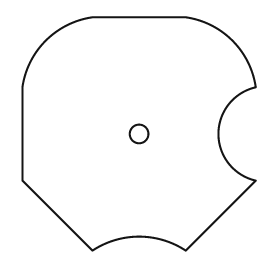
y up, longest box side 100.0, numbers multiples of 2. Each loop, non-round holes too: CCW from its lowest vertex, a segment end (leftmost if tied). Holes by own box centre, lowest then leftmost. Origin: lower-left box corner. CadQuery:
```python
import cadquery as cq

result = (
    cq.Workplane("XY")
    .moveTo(30.0, 0.0)
    .threePointArc((50.0, 6.0), (70.0, 0.0))
    .lineTo(100.0, 30.0)
    .threePointArc((84.0, 50.0), (100.0, 70.0))
    .threePointArc((90.0, 90.0), (70.0, 100.0))
    .lineTo(30.0, 100.0)
    .threePointArc((10.0, 90.0), (0.0, 70.0))
    .lineTo(0.0, 30.0)
    .close()
    .moveTo(50.0, 50.0)
    .circle(4.0)
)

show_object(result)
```